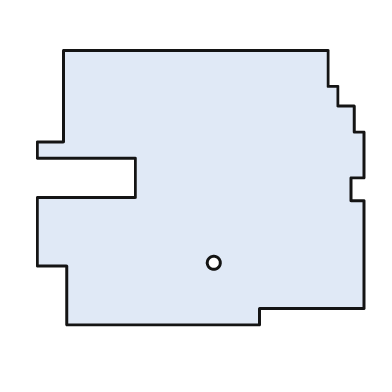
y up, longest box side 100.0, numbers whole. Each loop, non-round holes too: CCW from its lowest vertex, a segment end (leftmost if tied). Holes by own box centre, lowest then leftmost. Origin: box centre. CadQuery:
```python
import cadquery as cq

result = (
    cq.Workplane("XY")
    .moveTo(-41.0, -42.0)
    .lineTo(18.0, -42.0)
    .lineTo(18.0, -37.0)
    .lineTo(50.0, -37.0)
    .lineTo(50.0, -4.0)
    .lineTo(46.0, -4.0)
    .lineTo(46.0, 3.0)
    .lineTo(50.0, 3.0)
    .lineTo(50.0, 17.0)
    .lineTo(47.0, 17.0)
    .lineTo(47.0, 25.0)
    .lineTo(42.0, 25.0)
    .lineTo(42.0, 31.0)
    .lineTo(39.0, 31.0)
    .lineTo(39.0, 42.0)
    .lineTo(-42.0, 42.0)
    .lineTo(-42.0, 14.0)
    .lineTo(-50.0, 14.0)
    .lineTo(-50.0, 9.0)
    .lineTo(-20.0, 9.0)
    .lineTo(-20.0, -3.0)
    .lineTo(-50.0, -3.0)
    .lineTo(-50.0, -24.0)
    .lineTo(-41.0, -24.0)
    .close()
    .moveTo(4.0, -23.0)
    .circle(2.0)
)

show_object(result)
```